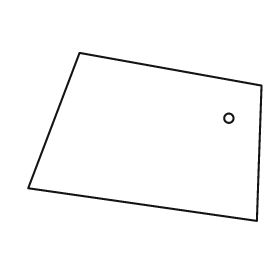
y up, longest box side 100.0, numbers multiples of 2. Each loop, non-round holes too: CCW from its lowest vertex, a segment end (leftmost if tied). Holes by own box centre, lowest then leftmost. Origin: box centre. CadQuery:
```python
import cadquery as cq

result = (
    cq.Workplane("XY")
    .moveTo(48.0, -36.0)
    .lineTo(50.0, 22.0)
    .lineTo(-28.0, 36.0)
    .lineTo(-50.0, -22.0)
    .close()
    .moveTo(36.0, 8.0)
    .circle(2.0)
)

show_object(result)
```